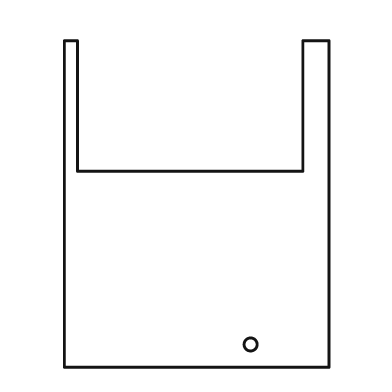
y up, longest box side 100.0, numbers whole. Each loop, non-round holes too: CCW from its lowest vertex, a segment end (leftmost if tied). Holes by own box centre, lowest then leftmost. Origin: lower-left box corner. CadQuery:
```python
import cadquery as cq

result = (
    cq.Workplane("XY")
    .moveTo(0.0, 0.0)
    .lineTo(81.0, 0.0)
    .lineTo(81.0, 100.0)
    .lineTo(73.0, 100.0)
    .lineTo(73.0, 60.0)
    .lineTo(4.0, 60.0)
    .lineTo(4.0, 100.0)
    .lineTo(0.0, 100.0)
    .close()
    .moveTo(57.0, 7.0)
    .circle(2.0)
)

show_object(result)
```